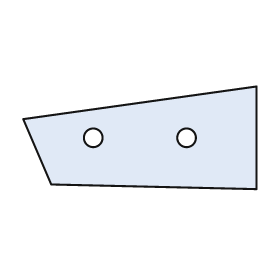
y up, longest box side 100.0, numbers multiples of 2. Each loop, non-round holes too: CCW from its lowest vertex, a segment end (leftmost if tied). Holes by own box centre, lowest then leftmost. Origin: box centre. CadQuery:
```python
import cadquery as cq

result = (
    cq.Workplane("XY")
    .moveTo(50.0, -22.0)
    .lineTo(50.0, 22.0)
    .lineTo(-50.0, 8.0)
    .lineTo(-38.0, -20.0)
    .close()
    .moveTo(-20.0, 0.0)
    .circle(4.0)
    .moveTo(20.0, 0.0)
    .circle(4.0)
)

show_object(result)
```